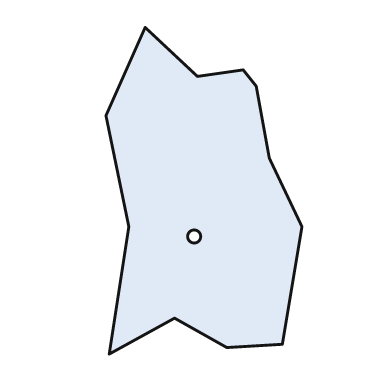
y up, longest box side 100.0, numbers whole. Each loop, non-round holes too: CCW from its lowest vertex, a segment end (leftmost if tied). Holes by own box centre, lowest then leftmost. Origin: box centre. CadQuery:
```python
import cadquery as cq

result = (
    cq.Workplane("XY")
    .moveTo(-29.0, -50.0)
    .lineTo(-9.0, -39.0)
    .lineTo(7.0, -48.0)
    .lineTo(24.0, -47.0)
    .lineTo(30.0, -11.0)
    .lineTo(20.0, 10.0)
    .lineTo(16.0, 32.0)
    .lineTo(12.0, 37.0)
    .lineTo(-2.0, 35.0)
    .lineTo(-18.0, 50.0)
    .lineTo(-30.0, 23.0)
    .lineTo(-23.0, -11.0)
    .close()
    .moveTo(-3.0, -14.0)
    .circle(2.0)
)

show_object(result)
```